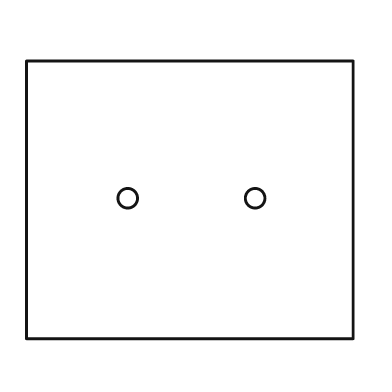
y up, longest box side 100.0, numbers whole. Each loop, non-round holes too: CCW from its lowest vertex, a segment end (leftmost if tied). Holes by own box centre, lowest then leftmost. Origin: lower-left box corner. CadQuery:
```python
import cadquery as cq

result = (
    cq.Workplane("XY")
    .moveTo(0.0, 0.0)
    .lineTo(100.0, 0.0)
    .lineTo(100.0, 85.0)
    .lineTo(0.0, 85.0)
    .close()
    .moveTo(31.0, 43.0)
    .circle(3.0)
    .moveTo(70.0, 43.0)
    .circle(3.0)
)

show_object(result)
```